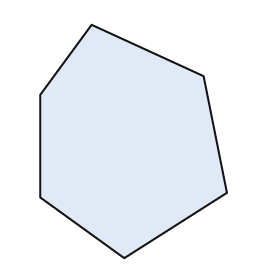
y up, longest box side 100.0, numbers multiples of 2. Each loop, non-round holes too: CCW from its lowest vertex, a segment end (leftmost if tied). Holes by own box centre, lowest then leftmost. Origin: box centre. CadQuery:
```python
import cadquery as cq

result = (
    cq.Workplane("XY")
    .moveTo(-4.0, -50.0)
    .lineTo(40.0, -22.0)
    .lineTo(30.0, 28.0)
    .lineTo(-18.0, 50.0)
    .lineTo(-40.0, 20.0)
    .lineTo(-40.0, -24.0)
    .close()
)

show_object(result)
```